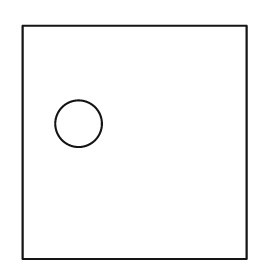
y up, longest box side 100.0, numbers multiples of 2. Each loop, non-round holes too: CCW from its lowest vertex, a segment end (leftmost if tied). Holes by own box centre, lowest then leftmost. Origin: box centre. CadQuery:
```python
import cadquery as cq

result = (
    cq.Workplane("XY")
    .moveTo(-48.0, -50.0)
    .lineTo(48.0, -50.0)
    .lineTo(48.0, 50.0)
    .lineTo(-48.0, 50.0)
    .close()
    .moveTo(-24.0, 8.0)
    .circle(10.0)
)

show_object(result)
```